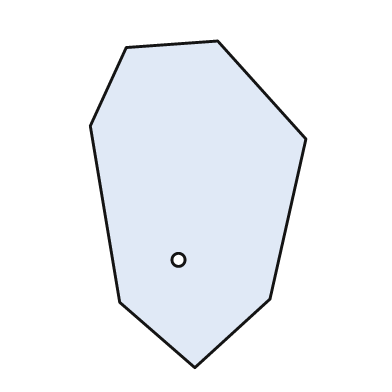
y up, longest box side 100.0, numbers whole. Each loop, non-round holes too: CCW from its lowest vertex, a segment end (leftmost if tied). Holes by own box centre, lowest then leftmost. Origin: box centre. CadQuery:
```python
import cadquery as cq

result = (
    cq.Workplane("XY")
    .moveTo(-1.0, -50.0)
    .lineTo(22.0, -29.0)
    .lineTo(33.0, 20.0)
    .lineTo(6.0, 50.0)
    .lineTo(-22.0, 48.0)
    .lineTo(-33.0, 24.0)
    .lineTo(-24.0, -30.0)
    .close()
    .moveTo(-6.0, -17.0)
    .circle(2.0)
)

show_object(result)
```